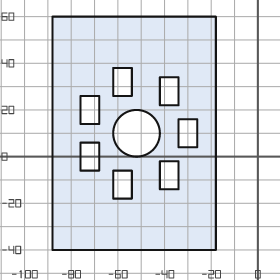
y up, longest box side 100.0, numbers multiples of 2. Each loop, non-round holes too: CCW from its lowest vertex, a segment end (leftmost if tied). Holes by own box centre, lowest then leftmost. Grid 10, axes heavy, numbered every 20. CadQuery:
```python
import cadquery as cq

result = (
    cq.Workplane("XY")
    .moveTo(-88.0, -40.0)
    .lineTo(-18.0, -40.0)
    .lineTo(-18.0, 60.0)
    .lineTo(-88.0, 60.0)
    .close()
    .moveTo(-62.0, -18.0)
    .lineTo(-54.0, -18.0)
    .lineTo(-54.0, -6.0)
    .lineTo(-62.0, -6.0)
    .close()
    .moveTo(-42.0, -14.0)
    .lineTo(-34.0, -14.0)
    .lineTo(-34.0, -2.0)
    .lineTo(-42.0, -2.0)
    .close()
    .moveTo(-76.0, -6.0)
    .lineTo(-68.0, -6.0)
    .lineTo(-68.0, 6.0)
    .lineTo(-76.0, 6.0)
    .close()
    .moveTo(-52.0, 10.0)
    .circle(10.0)
    .moveTo(-34.0, 4.0)
    .lineTo(-26.0, 4.0)
    .lineTo(-26.0, 16.0)
    .lineTo(-34.0, 16.0)
    .close()
    .moveTo(-76.0, 14.0)
    .lineTo(-68.0, 14.0)
    .lineTo(-68.0, 26.0)
    .lineTo(-76.0, 26.0)
    .close()
    .moveTo(-42.0, 22.0)
    .lineTo(-34.0, 22.0)
    .lineTo(-34.0, 34.0)
    .lineTo(-42.0, 34.0)
    .close()
    .moveTo(-62.0, 26.0)
    .lineTo(-54.0, 26.0)
    .lineTo(-54.0, 38.0)
    .lineTo(-62.0, 38.0)
    .close()
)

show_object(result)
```